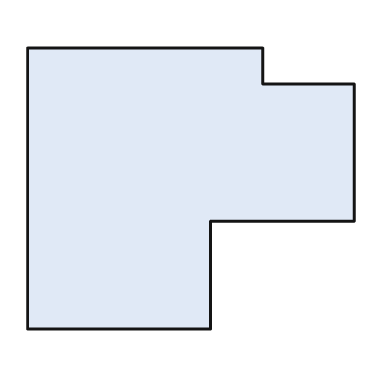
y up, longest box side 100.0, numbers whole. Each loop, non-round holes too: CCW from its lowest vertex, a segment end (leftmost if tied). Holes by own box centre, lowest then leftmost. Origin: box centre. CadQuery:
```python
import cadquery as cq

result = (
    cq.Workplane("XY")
    .moveTo(-50.0, -43.0)
    .lineTo(6.0, -43.0)
    .lineTo(6.0, -10.0)
    .lineTo(50.0, -10.0)
    .lineTo(50.0, 32.0)
    .lineTo(22.0, 32.0)
    .lineTo(22.0, 43.0)
    .lineTo(-50.0, 43.0)
    .close()
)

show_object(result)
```